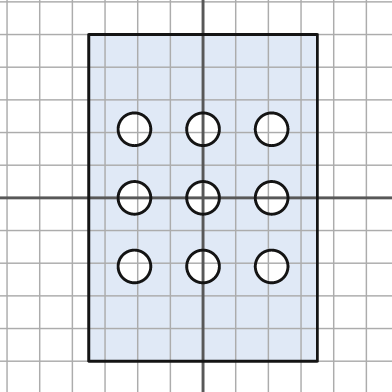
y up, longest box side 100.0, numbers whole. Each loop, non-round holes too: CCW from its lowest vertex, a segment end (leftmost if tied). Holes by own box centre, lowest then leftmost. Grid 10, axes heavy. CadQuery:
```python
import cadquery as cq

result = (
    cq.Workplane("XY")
    .moveTo(-35.0, -50.0)
    .lineTo(35.0, -50.0)
    .lineTo(35.0, 50.0)
    .lineTo(-35.0, 50.0)
    .close()
    .moveTo(-21.0, -21.0)
    .circle(5.0)
    .moveTo(0.0, -21.0)
    .circle(5.0)
    .moveTo(21.0, -21.0)
    .circle(5.0)
    .moveTo(-21.0, 0.0)
    .circle(5.0)
    .moveTo(0.0, 0.0)
    .circle(5.0)
    .moveTo(21.0, 0.0)
    .circle(5.0)
    .moveTo(-21.0, 21.0)
    .circle(5.0)
    .moveTo(0.0, 21.0)
    .circle(5.0)
    .moveTo(21.0, 21.0)
    .circle(5.0)
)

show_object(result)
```